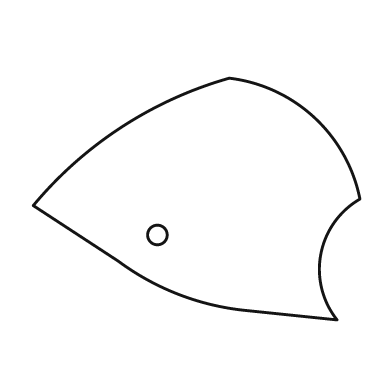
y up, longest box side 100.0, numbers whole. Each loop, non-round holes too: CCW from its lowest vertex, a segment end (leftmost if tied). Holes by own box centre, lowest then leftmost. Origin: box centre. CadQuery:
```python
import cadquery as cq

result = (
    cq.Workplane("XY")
    .moveTo(43.0, -37.0)
    .threePointArc((38.0, -17.0), (50.0, 0.0))
    .threePointArc((36.0, 25.0), (10.0, 37.0))
    .threePointArc((-23.0, 22.0), (-50.0, -2.0))
    .lineTo(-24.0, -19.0)
    .threePointArc((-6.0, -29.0), (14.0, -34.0))
    .close()
    .moveTo(-12.0, -11.0)
    .circle(3.0)
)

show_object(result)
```